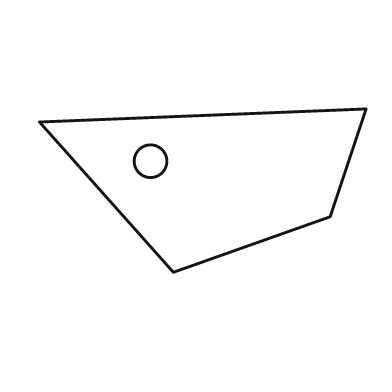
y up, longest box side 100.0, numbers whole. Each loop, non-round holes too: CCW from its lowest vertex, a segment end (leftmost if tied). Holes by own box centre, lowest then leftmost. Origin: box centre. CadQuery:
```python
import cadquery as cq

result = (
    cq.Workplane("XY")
    .moveTo(-9.0, -25.0)
    .lineTo(39.0, -8.0)
    .lineTo(50.0, 25.0)
    .lineTo(-50.0, 21.0)
    .close()
    .moveTo(-16.0, 9.0)
    .circle(5.0)
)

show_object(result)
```